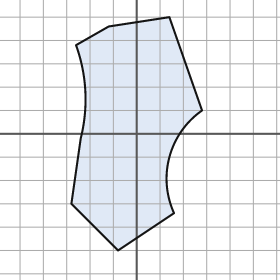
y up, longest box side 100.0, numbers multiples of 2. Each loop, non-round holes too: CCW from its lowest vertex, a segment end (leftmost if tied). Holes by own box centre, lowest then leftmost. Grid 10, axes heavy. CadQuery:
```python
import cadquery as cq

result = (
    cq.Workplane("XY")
    .moveTo(-8.0, -50.0)
    .lineTo(16.0, -34.0)
    .threePointArc((14.0, -10.0), (28.0, 10.0))
    .lineTo(14.0, 50.0)
    .lineTo(-12.0, 46.0)
    .lineTo(-26.0, 38.0)
    .threePointArc((-22.0, 18.0), (-24.0, -2.0))
    .lineTo(-28.0, -30.0)
    .close()
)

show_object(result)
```